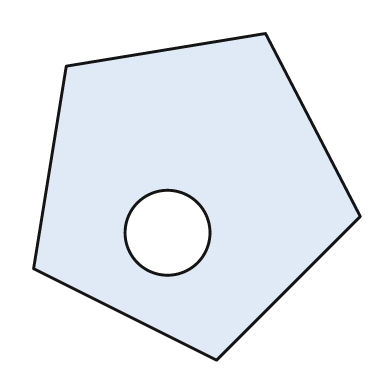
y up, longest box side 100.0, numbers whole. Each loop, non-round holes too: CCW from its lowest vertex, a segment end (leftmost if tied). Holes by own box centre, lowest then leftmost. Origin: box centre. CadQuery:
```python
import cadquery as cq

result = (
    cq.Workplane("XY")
    .moveTo(6.0, -50.0)
    .lineTo(50.0, -6.0)
    .lineTo(21.0, 50.0)
    .lineTo(-40.0, 40.0)
    .lineTo(-50.0, -22.0)
    .close()
    .moveTo(-9.0, -11.0)
    .circle(13.0)
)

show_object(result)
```